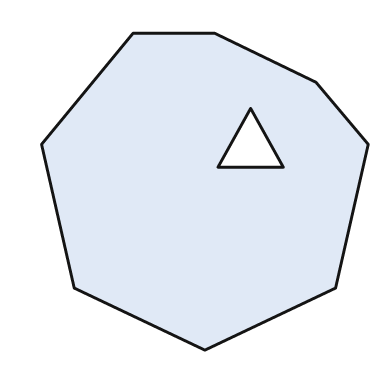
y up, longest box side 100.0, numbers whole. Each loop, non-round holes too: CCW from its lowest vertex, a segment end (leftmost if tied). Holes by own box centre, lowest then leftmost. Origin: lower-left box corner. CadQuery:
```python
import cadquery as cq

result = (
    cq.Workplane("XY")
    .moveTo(50.0, 0.0)
    .lineTo(90.0, 19.0)
    .lineTo(100.0, 63.0)
    .lineTo(84.0, 82.0)
    .lineTo(53.0, 97.0)
    .lineTo(28.0, 97.0)
    .lineTo(0.0, 63.0)
    .lineTo(10.0, 19.0)
    .close()
    .moveTo(54.0, 56.0)
    .lineTo(74.0, 56.0)
    .lineTo(64.0, 74.0)
    .close()
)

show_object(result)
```